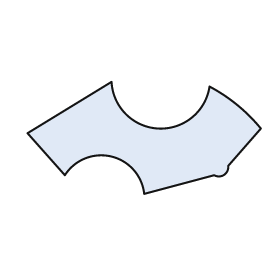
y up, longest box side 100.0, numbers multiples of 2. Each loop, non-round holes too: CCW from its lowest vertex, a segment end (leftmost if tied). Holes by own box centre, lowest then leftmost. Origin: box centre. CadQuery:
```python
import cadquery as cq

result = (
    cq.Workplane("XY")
    .moveTo(0.0, -24.0)
    .lineTo(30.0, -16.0)
    .threePointArc((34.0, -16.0), (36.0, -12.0))
    .lineTo(50.0, 4.0)
    .threePointArc((40.0, 14.0), (28.0, 22.0))
    .threePointArc((6.0, 4.0), (-14.0, 24.0))
    .lineTo(-50.0, 2.0)
    .lineTo(-34.0, -16.0)
    .threePointArc((-14.0, -8.0), (0.0, -24.0))
    .close()
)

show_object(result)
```